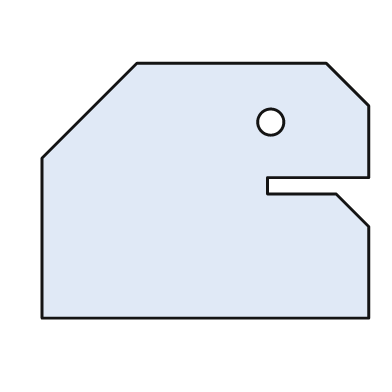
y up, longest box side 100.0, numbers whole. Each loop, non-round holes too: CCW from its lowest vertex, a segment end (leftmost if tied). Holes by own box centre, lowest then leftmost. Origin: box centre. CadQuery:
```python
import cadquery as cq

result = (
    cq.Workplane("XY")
    .moveTo(-50.0, -39.0)
    .lineTo(50.0, -39.0)
    .lineTo(50.0, -11.0)
    .lineTo(40.0, -1.0)
    .lineTo(19.0, -1.0)
    .lineTo(19.0, 4.0)
    .lineTo(50.0, 4.0)
    .lineTo(50.0, 26.0)
    .lineTo(37.0, 39.0)
    .lineTo(-21.0, 39.0)
    .lineTo(-50.0, 10.0)
    .close()
    .moveTo(20.0, 21.0)
    .circle(4.0)
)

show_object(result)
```